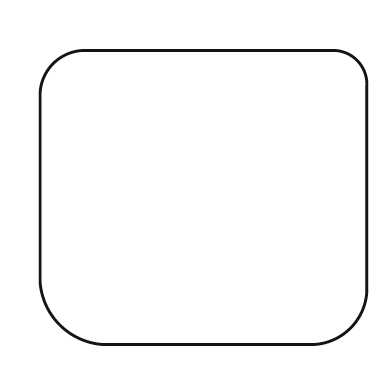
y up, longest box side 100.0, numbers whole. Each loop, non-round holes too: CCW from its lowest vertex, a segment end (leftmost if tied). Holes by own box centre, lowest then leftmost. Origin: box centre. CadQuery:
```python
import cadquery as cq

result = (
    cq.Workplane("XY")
    .moveTo(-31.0, -45.0)
    .lineTo(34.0, -45.0)
    .threePointArc((45.0, -40.0), (50.0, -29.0))
    .lineTo(50.0, 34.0)
    .threePointArc((47.0, 42.0), (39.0, 45.0))
    .lineTo(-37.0, 45.0)
    .threePointArc((-46.0, 41.0), (-50.0, 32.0))
    .lineTo(-50.0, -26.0)
    .threePointArc((-44.0, -39.0), (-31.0, -45.0))
    .close()
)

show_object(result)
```